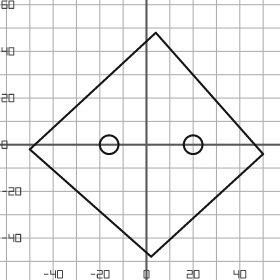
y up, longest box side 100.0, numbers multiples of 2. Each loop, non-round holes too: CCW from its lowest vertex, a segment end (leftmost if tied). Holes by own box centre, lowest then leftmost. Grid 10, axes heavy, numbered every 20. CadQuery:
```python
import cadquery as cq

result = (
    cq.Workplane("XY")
    .moveTo(2.0, -48.0)
    .lineTo(50.0, -4.0)
    .lineTo(4.0, 48.0)
    .lineTo(-50.0, -2.0)
    .close()
    .moveTo(-16.0, 0.0)
    .circle(4.0)
    .moveTo(20.0, 0.0)
    .circle(4.0)
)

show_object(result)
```